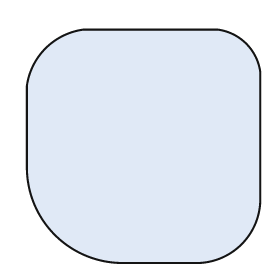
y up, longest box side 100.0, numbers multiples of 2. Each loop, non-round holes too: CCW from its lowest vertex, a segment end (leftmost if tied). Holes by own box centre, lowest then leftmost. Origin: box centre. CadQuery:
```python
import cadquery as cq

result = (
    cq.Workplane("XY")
    .moveTo(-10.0, -50.0)
    .lineTo(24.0, -50.0)
    .threePointArc((42.0, -42.0), (50.0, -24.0))
    .lineTo(50.0, 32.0)
    .threePointArc((44.0, 44.0), (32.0, 50.0))
    .lineTo(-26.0, 50.0)
    .threePointArc((-42.0, 42.0), (-50.0, 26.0))
    .lineTo(-50.0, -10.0)
    .threePointArc((-38.0, -38.0), (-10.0, -50.0))
    .close()
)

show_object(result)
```